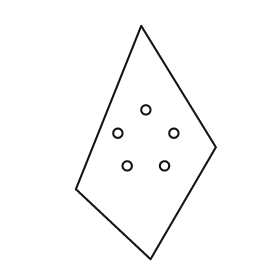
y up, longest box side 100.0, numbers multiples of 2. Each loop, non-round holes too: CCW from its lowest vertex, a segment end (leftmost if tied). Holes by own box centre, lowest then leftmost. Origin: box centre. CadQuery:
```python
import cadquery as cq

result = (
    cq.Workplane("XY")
    .moveTo(2.0, -50.0)
    .lineTo(30.0, -2.0)
    .lineTo(-2.0, 50.0)
    .lineTo(-30.0, -20.0)
    .close()
    .moveTo(-8.0, -10.0)
    .circle(2.0)
    .moveTo(8.0, -10.0)
    .circle(2.0)
    .moveTo(-12.0, 4.0)
    .circle(2.0)
    .moveTo(12.0, 4.0)
    .circle(2.0)
    .moveTo(0.0, 14.0)
    .circle(2.0)
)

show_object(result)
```